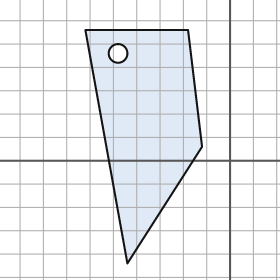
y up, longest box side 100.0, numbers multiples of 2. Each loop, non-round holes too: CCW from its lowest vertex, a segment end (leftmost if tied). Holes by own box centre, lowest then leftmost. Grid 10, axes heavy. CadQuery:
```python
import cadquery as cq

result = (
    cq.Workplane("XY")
    .moveTo(-44.0, -44.0)
    .lineTo(-12.0, 6.0)
    .lineTo(-18.0, 56.0)
    .lineTo(-62.0, 56.0)
    .close()
    .moveTo(-48.0, 46.0)
    .circle(4.0)
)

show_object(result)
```